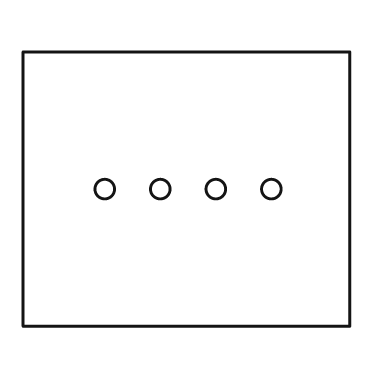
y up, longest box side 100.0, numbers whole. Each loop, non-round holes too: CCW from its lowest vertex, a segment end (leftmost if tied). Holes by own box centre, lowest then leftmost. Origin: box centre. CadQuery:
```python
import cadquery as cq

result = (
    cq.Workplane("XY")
    .moveTo(-50.0, -42.0)
    .lineTo(50.0, -42.0)
    .lineTo(50.0, 42.0)
    .lineTo(-50.0, 42.0)
    .close()
    .moveTo(-25.0, 0.0)
    .circle(3.0)
    .moveTo(-8.0, 0.0)
    .circle(3.0)
    .moveTo(9.0, 0.0)
    .circle(3.0)
    .moveTo(26.0, 0.0)
    .circle(3.0)
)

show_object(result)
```